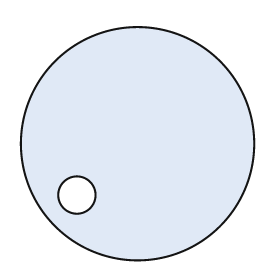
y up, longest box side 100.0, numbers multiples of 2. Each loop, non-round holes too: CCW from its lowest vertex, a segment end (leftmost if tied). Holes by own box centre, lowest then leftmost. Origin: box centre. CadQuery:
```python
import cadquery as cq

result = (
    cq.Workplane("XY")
    .moveTo(0.0, 0.0)
    .circle(50.0)
    .moveTo(-26.0, -22.0)
    .circle(8.0)
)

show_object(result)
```